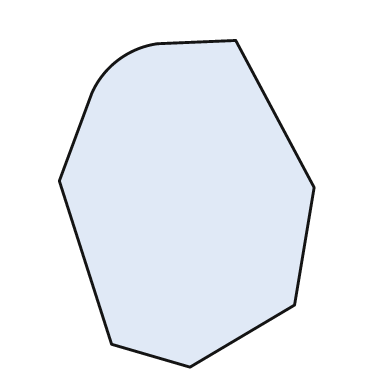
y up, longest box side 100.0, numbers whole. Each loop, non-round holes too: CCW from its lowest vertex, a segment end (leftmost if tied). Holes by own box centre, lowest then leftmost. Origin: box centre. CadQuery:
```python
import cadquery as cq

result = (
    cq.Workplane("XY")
    .moveTo(1.0, -50.0)
    .lineTo(33.0, -31.0)
    .lineTo(39.0, 5.0)
    .lineTo(15.0, 50.0)
    .lineTo(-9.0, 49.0)
    .threePointArc((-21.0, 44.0), (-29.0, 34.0))
    .lineTo(-39.0, 7.0)
    .lineTo(-23.0, -43.0)
    .close()
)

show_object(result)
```